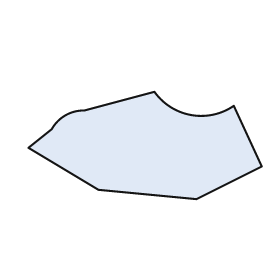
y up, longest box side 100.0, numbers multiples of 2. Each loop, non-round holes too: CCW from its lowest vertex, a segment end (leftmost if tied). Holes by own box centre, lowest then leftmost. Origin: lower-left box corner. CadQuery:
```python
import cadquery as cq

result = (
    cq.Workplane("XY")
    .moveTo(72.0, 0.0)
    .lineTo(100.0, 14.0)
    .lineTo(88.0, 40.0)
    .threePointArc((70.0, 36.0), (54.0, 46.0))
    .lineTo(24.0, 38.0)
    .threePointArc((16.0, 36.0), (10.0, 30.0))
    .lineTo(0.0, 22.0)
    .lineTo(30.0, 4.0)
    .close()
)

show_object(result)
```